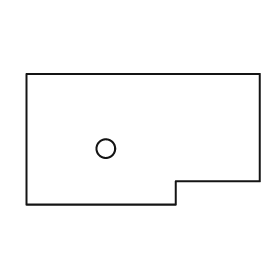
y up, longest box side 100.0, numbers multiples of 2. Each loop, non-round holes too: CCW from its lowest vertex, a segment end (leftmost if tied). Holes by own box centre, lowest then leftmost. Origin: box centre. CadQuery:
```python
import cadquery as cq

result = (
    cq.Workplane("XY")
    .moveTo(-50.0, -28.0)
    .lineTo(14.0, -28.0)
    .lineTo(14.0, -18.0)
    .lineTo(50.0, -18.0)
    .lineTo(50.0, 28.0)
    .lineTo(-50.0, 28.0)
    .close()
    .moveTo(-16.0, -4.0)
    .circle(4.0)
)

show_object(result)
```